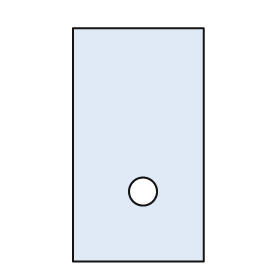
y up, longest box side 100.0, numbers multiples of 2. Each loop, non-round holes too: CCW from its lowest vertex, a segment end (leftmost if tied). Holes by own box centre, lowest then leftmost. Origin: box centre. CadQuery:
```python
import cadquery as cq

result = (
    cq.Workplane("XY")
    .moveTo(-28.0, -50.0)
    .lineTo(28.0, -50.0)
    .lineTo(28.0, 50.0)
    .lineTo(-28.0, 50.0)
    .close()
    .moveTo(2.0, -20.0)
    .circle(6.0)
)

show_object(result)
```